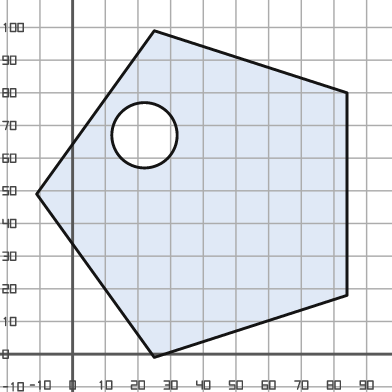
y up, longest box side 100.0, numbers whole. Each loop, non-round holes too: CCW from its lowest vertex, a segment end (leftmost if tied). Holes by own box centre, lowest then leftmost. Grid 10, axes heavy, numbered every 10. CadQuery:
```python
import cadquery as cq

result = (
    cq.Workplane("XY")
    .moveTo(25.0, -1.0)
    .lineTo(84.0, 18.0)
    .lineTo(84.0, 80.0)
    .lineTo(25.0, 99.0)
    .lineTo(-11.0, 49.0)
    .close()
    .moveTo(22.0, 67.0)
    .circle(10.0)
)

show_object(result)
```